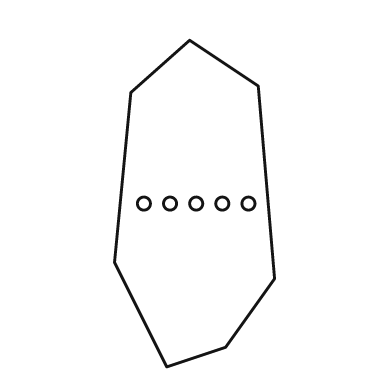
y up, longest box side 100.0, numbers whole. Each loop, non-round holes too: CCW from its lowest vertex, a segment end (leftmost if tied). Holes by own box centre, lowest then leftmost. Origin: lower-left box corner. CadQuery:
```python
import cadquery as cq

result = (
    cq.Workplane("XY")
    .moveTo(16.0, 0.0)
    .lineTo(34.0, 6.0)
    .lineTo(49.0, 27.0)
    .lineTo(44.0, 86.0)
    .lineTo(23.0, 100.0)
    .lineTo(5.0, 84.0)
    .lineTo(0.0, 32.0)
    .close()
    .moveTo(9.0, 50.0)
    .circle(2.0)
    .moveTo(17.0, 50.0)
    .circle(2.0)
    .moveTo(25.0, 50.0)
    .circle(2.0)
    .moveTo(33.0, 50.0)
    .circle(2.0)
    .moveTo(41.0, 50.0)
    .circle(2.0)
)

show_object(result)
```